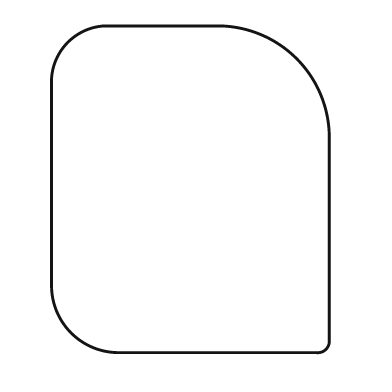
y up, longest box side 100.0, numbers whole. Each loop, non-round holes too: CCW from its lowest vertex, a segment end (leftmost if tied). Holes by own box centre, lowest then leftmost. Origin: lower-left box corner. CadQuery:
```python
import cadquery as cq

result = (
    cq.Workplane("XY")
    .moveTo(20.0, 0.0)
    .lineTo(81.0, 0.0)
    .threePointArc((84.0, 1.0), (85.0, 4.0))
    .lineTo(85.0, 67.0)
    .threePointArc((75.0, 90.0), (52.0, 100.0))
    .lineTo(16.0, 100.0)
    .threePointArc((5.0, 95.0), (0.0, 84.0))
    .lineTo(0.0, 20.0)
    .threePointArc((6.0, 6.0), (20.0, 0.0))
    .close()
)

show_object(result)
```